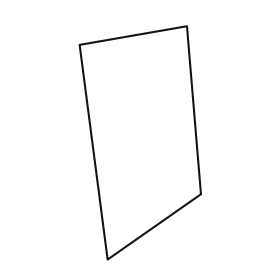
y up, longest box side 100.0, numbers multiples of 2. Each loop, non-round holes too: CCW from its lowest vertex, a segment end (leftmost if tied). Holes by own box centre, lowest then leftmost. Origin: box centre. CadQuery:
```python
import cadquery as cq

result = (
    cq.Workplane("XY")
    .moveTo(-14.0, -50.0)
    .lineTo(26.0, -22.0)
    .lineTo(20.0, 50.0)
    .lineTo(-26.0, 42.0)
    .close()
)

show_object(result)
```